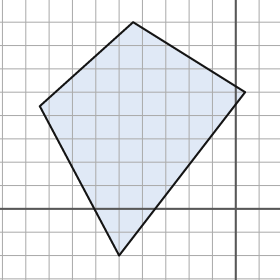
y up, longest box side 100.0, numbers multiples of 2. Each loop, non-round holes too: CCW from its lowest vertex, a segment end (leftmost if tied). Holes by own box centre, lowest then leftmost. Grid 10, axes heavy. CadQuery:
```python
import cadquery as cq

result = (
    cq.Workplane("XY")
    .moveTo(-50.0, -20.0)
    .lineTo(4.0, 50.0)
    .lineTo(-44.0, 80.0)
    .lineTo(-84.0, 44.0)
    .close()
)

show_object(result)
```